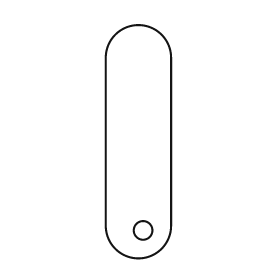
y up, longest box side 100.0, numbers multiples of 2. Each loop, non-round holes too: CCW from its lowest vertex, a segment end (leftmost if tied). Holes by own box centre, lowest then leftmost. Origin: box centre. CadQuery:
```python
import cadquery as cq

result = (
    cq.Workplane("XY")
    .moveTo(-14.0, -36.0)
    .threePointArc((0.0, -50.0), (14.0, -36.0))
    .lineTo(14.0, 36.0)
    .threePointArc((0.0, 50.0), (-14.0, 36.0))
    .close()
    .moveTo(2.0, -38.0)
    .circle(4.0)
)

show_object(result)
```